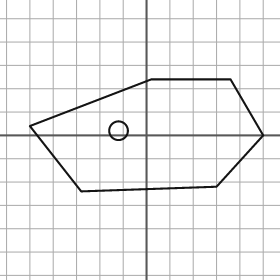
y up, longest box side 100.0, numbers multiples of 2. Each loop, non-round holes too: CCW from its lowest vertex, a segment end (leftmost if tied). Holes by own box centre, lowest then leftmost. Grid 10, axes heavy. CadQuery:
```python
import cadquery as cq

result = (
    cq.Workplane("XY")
    .moveTo(-28.0, -24.0)
    .lineTo(30.0, -22.0)
    .lineTo(50.0, 0.0)
    .lineTo(36.0, 24.0)
    .lineTo(2.0, 24.0)
    .lineTo(-50.0, 4.0)
    .close()
    .moveTo(-12.0, 2.0)
    .circle(4.0)
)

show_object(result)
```